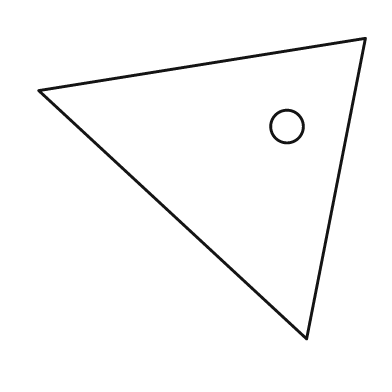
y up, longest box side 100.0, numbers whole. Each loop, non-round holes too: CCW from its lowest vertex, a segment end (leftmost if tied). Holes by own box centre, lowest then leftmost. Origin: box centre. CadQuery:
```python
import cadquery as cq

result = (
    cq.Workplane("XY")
    .moveTo(32.0, -46.0)
    .lineTo(50.0, 46.0)
    .lineTo(-50.0, 30.0)
    .close()
    .moveTo(26.0, 19.0)
    .circle(5.0)
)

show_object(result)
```